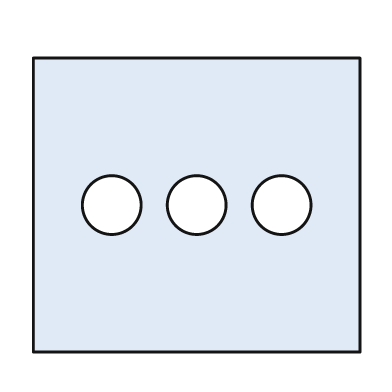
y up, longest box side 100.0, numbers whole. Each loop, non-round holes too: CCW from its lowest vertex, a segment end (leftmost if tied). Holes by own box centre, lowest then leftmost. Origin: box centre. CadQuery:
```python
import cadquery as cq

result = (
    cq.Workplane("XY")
    .moveTo(-50.0, -45.0)
    .lineTo(50.0, -45.0)
    .lineTo(50.0, 45.0)
    .lineTo(-50.0, 45.0)
    .close()
    .moveTo(-26.0, 0.0)
    .circle(9.0)
    .moveTo(0.0, 0.0)
    .circle(9.0)
    .moveTo(26.0, 0.0)
    .circle(9.0)
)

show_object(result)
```